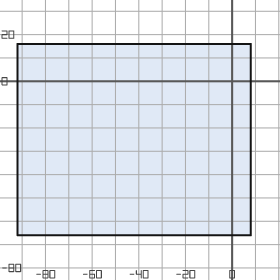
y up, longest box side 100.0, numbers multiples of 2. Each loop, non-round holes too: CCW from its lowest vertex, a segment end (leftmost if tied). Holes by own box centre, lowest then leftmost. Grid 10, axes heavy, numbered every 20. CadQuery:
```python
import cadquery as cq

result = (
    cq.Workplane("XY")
    .moveTo(-92.0, -66.0)
    .lineTo(8.0, -66.0)
    .lineTo(8.0, 16.0)
    .lineTo(-92.0, 16.0)
    .close()
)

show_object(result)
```